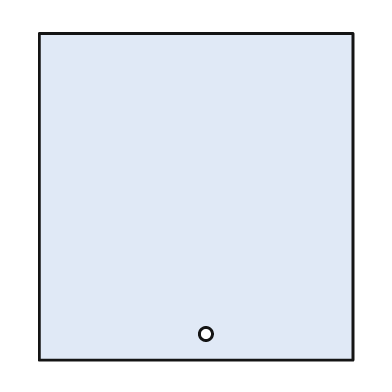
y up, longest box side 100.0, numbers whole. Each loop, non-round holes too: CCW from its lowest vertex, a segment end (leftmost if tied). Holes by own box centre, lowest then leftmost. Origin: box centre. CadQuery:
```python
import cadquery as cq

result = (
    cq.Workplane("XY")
    .moveTo(-48.0, -50.0)
    .lineTo(48.0, -50.0)
    .lineTo(48.0, 50.0)
    .lineTo(-48.0, 50.0)
    .close()
    .moveTo(3.0, -42.0)
    .circle(2.0)
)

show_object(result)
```